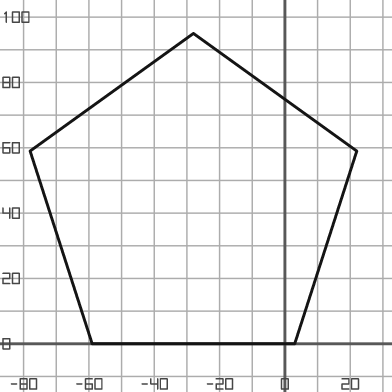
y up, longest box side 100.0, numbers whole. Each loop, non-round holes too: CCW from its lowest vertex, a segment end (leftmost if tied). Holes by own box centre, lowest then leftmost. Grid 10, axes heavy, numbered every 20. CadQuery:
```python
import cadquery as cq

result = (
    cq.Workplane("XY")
    .moveTo(-59.0, 0.0)
    .lineTo(3.0, 0.0)
    .lineTo(22.0, 59.0)
    .lineTo(-28.0, 95.0)
    .lineTo(-78.0, 59.0)
    .close()
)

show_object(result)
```